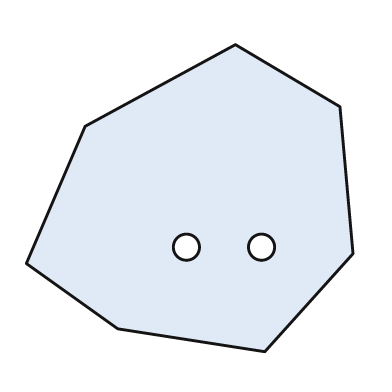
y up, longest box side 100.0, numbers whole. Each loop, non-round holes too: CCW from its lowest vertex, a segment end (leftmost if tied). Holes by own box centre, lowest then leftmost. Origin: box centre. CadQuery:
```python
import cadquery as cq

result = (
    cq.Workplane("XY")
    .moveTo(23.0, -47.0)
    .lineTo(50.0, -17.0)
    .lineTo(46.0, 28.0)
    .lineTo(14.0, 47.0)
    .lineTo(-32.0, 22.0)
    .lineTo(-50.0, -20.0)
    .lineTo(-22.0, -40.0)
    .close()
    .moveTo(-1.0, -15.0)
    .circle(4.0)
    .moveTo(22.0, -15.0)
    .circle(4.0)
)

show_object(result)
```